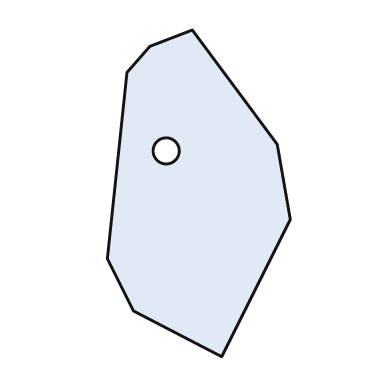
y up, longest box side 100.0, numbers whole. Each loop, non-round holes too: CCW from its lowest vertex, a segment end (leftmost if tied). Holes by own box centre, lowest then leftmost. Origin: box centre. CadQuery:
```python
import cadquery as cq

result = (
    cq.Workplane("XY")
    .moveTo(7.0, -50.0)
    .lineTo(28.0, -8.0)
    .lineTo(24.0, 15.0)
    .lineTo(-2.0, 50.0)
    .lineTo(-15.0, 45.0)
    .lineTo(-22.0, 37.0)
    .lineTo(-28.0, -20.0)
    .lineTo(-20.0, -36.0)
    .close()
    .moveTo(-10.0, 13.0)
    .circle(4.0)
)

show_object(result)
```